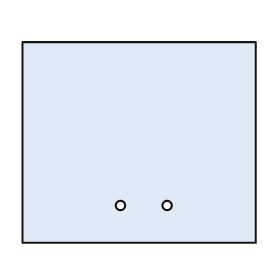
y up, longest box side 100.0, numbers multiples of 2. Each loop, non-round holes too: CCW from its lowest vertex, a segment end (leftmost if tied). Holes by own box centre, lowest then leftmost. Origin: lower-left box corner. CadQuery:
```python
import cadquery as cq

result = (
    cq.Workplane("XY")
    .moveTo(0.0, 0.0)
    .lineTo(100.0, 0.0)
    .lineTo(100.0, 86.0)
    .lineTo(0.0, 86.0)
    .close()
    .moveTo(42.0, 16.0)
    .circle(2.0)
    .moveTo(62.0, 16.0)
    .circle(2.0)
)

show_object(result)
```